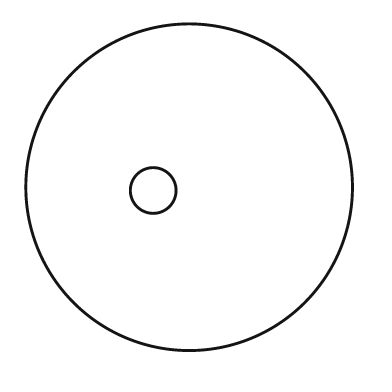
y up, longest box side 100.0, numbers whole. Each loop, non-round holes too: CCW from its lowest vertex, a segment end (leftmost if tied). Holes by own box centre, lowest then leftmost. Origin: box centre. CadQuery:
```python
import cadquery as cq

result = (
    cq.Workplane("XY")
    .moveTo(0.0, 0.0)
    .circle(50.0)
    .moveTo(-11.0, -1.0)
    .circle(7.0)
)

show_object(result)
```